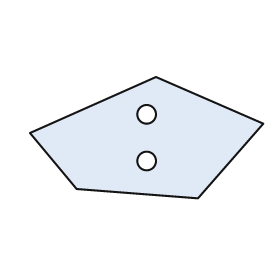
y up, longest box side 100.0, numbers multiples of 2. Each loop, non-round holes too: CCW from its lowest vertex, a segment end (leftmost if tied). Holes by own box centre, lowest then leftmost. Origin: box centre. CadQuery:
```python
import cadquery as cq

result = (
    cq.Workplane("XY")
    .moveTo(22.0, -26.0)
    .lineTo(50.0, 6.0)
    .lineTo(4.0, 26.0)
    .lineTo(-50.0, 2.0)
    .lineTo(-30.0, -22.0)
    .close()
    .moveTo(0.0, -10.0)
    .circle(4.0)
    .moveTo(0.0, 10.0)
    .circle(4.0)
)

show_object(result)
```